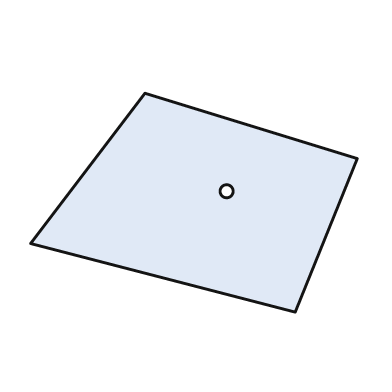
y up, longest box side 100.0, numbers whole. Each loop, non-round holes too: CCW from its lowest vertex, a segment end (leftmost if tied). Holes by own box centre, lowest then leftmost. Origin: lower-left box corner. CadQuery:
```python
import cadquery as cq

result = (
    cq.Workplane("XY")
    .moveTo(81.0, 0.0)
    .lineTo(100.0, 47.0)
    .lineTo(35.0, 67.0)
    .lineTo(0.0, 21.0)
    .close()
    .moveTo(60.0, 37.0)
    .circle(2.0)
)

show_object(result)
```